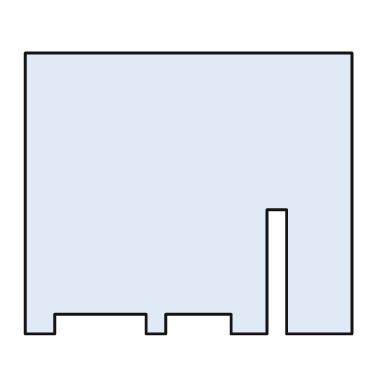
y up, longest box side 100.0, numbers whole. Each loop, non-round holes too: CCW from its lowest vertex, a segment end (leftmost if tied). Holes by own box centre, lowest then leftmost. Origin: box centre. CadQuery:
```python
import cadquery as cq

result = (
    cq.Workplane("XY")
    .moveTo(-50.0, -43.0)
    .lineTo(-41.0, -43.0)
    .lineTo(-41.0, -37.0)
    .lineTo(-13.0, -37.0)
    .lineTo(-13.0, -43.0)
    .lineTo(-7.0, -43.0)
    .lineTo(-7.0, -37.0)
    .lineTo(13.0, -37.0)
    .lineTo(13.0, -43.0)
    .lineTo(24.0, -43.0)
    .lineTo(24.0, -5.0)
    .lineTo(30.0, -5.0)
    .lineTo(30.0, -43.0)
    .lineTo(50.0, -43.0)
    .lineTo(50.0, 43.0)
    .lineTo(-50.0, 43.0)
    .close()
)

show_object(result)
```